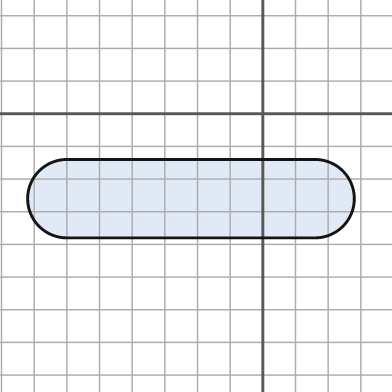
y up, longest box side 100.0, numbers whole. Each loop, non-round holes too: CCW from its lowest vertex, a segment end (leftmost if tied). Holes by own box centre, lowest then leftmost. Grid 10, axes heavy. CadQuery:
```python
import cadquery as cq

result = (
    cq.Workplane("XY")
    .moveTo(-60.0, -38.0)
    .lineTo(16.0, -38.0)
    .threePointArc((28.0, -26.0), (16.0, -14.0))
    .lineTo(-60.0, -14.0)
    .threePointArc((-72.0, -26.0), (-60.0, -38.0))
    .close()
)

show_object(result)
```